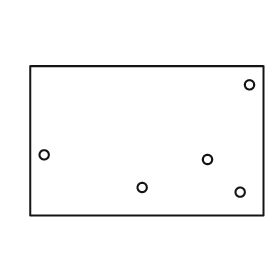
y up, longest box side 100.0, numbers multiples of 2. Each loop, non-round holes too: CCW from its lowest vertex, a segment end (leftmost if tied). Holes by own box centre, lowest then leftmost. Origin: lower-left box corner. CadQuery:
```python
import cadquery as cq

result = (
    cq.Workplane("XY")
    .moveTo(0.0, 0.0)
    .lineTo(100.0, 0.0)
    .lineTo(100.0, 64.0)
    .lineTo(0.0, 64.0)
    .close()
    .moveTo(90.0, 10.0)
    .circle(2.0)
    .moveTo(48.0, 12.0)
    .circle(2.0)
    .moveTo(76.0, 24.0)
    .circle(2.0)
    .moveTo(6.0, 26.0)
    .circle(2.0)
    .moveTo(94.0, 56.0)
    .circle(2.0)
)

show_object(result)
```